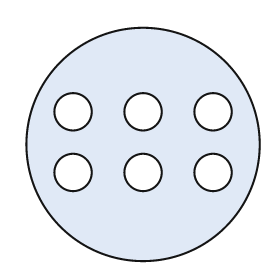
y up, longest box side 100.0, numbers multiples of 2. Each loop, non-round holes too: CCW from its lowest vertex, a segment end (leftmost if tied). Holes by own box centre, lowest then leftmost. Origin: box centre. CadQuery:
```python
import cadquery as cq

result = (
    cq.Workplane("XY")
    .moveTo(0.0, 0.0)
    .circle(50.0)
    .moveTo(-30.0, -12.0)
    .circle(8.0)
    .moveTo(0.0, -12.0)
    .circle(8.0)
    .moveTo(30.0, -12.0)
    .circle(8.0)
    .moveTo(-30.0, 14.0)
    .circle(8.0)
    .moveTo(0.0, 14.0)
    .circle(8.0)
    .moveTo(30.0, 14.0)
    .circle(8.0)
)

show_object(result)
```